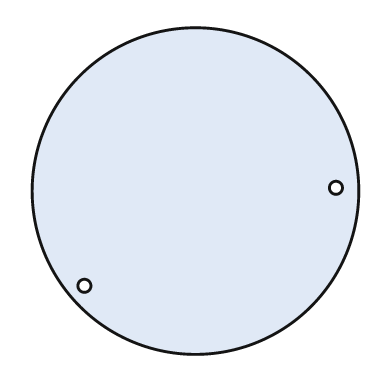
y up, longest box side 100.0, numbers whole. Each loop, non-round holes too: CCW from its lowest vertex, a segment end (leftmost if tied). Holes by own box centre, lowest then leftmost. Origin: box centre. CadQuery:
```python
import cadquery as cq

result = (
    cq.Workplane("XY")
    .moveTo(0.0, 0.0)
    .circle(50.0)
    .moveTo(-34.0, -29.0)
    .circle(2.0)
    .moveTo(43.0, 1.0)
    .circle(2.0)
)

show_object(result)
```